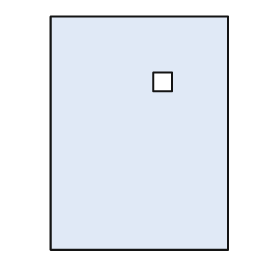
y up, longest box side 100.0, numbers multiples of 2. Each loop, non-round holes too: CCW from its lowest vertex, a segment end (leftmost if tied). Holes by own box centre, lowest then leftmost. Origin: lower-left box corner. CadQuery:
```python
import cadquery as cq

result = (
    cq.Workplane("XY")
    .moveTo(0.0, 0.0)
    .lineTo(76.0, 0.0)
    .lineTo(76.0, 100.0)
    .lineTo(0.0, 100.0)
    .close()
    .moveTo(44.0, 68.0)
    .lineTo(52.0, 68.0)
    .lineTo(52.0, 76.0)
    .lineTo(44.0, 76.0)
    .close()
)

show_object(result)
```